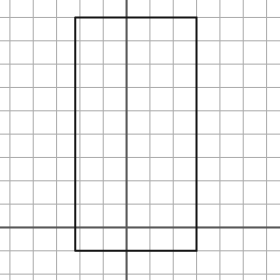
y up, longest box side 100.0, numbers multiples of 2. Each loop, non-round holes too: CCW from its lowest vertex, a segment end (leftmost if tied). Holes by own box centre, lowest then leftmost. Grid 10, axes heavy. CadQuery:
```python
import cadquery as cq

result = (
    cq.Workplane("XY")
    .moveTo(-22.0, -10.0)
    .lineTo(30.0, -10.0)
    .lineTo(30.0, 90.0)
    .lineTo(-22.0, 90.0)
    .close()
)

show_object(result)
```